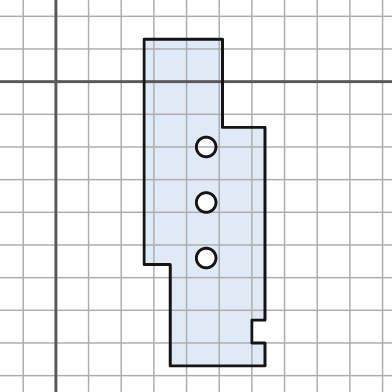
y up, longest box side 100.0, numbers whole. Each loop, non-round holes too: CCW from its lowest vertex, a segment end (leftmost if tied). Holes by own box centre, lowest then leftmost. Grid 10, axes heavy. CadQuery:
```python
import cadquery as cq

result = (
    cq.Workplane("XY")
    .moveTo(35.0, -87.0)
    .lineTo(64.0, -87.0)
    .lineTo(64.0, -80.0)
    .lineTo(60.0, -80.0)
    .lineTo(60.0, -73.0)
    .lineTo(64.0, -73.0)
    .lineTo(64.0, -14.0)
    .lineTo(51.0, -14.0)
    .lineTo(51.0, 13.0)
    .lineTo(27.0, 13.0)
    .lineTo(27.0, -56.0)
    .lineTo(35.0, -56.0)
    .close()
    .moveTo(46.0, -54.0)
    .circle(3.0)
    .moveTo(46.0, -37.0)
    .circle(3.0)
    .moveTo(46.0, -20.0)
    .circle(3.0)
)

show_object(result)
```